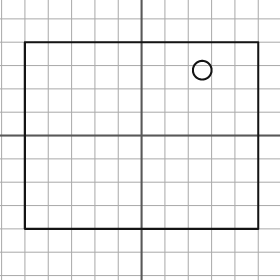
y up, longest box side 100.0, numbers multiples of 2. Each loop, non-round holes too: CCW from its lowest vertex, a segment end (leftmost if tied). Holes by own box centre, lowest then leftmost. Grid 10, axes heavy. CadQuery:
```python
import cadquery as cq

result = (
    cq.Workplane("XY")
    .moveTo(-50.0, -40.0)
    .lineTo(50.0, -40.0)
    .lineTo(50.0, 40.0)
    .lineTo(-50.0, 40.0)
    .close()
    .moveTo(26.0, 28.0)
    .circle(4.0)
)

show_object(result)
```